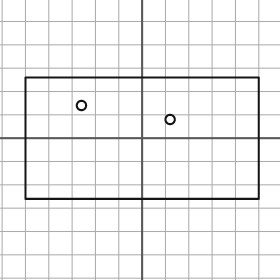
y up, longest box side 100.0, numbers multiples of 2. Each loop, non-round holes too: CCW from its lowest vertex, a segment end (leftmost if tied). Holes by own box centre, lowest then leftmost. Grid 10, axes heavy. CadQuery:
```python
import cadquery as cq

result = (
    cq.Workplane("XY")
    .moveTo(-50.0, -26.0)
    .lineTo(50.0, -26.0)
    .lineTo(50.0, 26.0)
    .lineTo(-50.0, 26.0)
    .close()
    .moveTo(12.0, 8.0)
    .circle(2.0)
    .moveTo(-26.0, 14.0)
    .circle(2.0)
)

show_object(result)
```